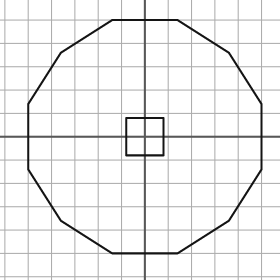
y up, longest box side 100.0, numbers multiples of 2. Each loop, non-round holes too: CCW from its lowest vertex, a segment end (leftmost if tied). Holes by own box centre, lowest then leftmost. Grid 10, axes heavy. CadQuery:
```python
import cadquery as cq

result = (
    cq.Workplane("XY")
    .moveTo(-14.0, -50.0)
    .lineTo(14.0, -50.0)
    .lineTo(36.0, -36.0)
    .lineTo(50.0, -14.0)
    .lineTo(50.0, 14.0)
    .lineTo(36.0, 36.0)
    .lineTo(14.0, 50.0)
    .lineTo(-14.0, 50.0)
    .lineTo(-36.0, 36.0)
    .lineTo(-50.0, 14.0)
    .lineTo(-50.0, -14.0)
    .lineTo(-36.0, -36.0)
    .close()
    .moveTo(-8.0, -8.0)
    .lineTo(8.0, -8.0)
    .lineTo(8.0, 8.0)
    .lineTo(-8.0, 8.0)
    .close()
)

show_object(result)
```